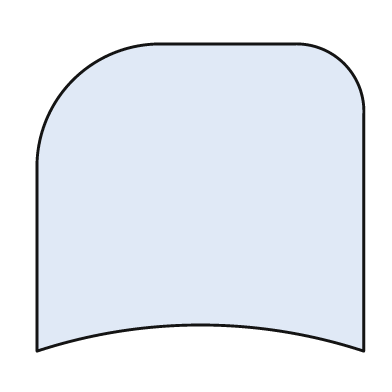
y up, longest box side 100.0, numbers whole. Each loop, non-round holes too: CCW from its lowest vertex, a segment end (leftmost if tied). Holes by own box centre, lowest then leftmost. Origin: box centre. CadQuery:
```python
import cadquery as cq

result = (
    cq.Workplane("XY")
    .moveTo(-50.0, -47.0)
    .threePointArc((0.0, -39.0), (50.0, -47.0))
    .lineTo(50.0, 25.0)
    .threePointArc((44.0, 41.0), (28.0, 47.0))
    .lineTo(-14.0, 47.0)
    .threePointArc((-39.0, 36.0), (-50.0, 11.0))
    .close()
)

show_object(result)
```